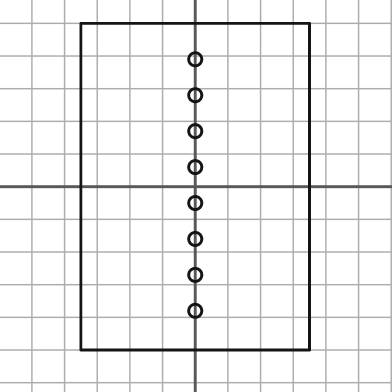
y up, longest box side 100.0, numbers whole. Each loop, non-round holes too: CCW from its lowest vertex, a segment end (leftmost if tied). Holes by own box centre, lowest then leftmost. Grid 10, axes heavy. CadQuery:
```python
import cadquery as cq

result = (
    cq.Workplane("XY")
    .moveTo(-35.0, -50.0)
    .lineTo(35.0, -50.0)
    .lineTo(35.0, 50.0)
    .lineTo(-35.0, 50.0)
    .close()
    .moveTo(0.0, -38.0)
    .circle(2.0)
    .moveTo(0.0, -27.0)
    .circle(2.0)
    .moveTo(0.0, -16.0)
    .circle(2.0)
    .moveTo(0.0, -5.0)
    .circle(2.0)
    .moveTo(0.0, 6.0)
    .circle(2.0)
    .moveTo(0.0, 17.0)
    .circle(2.0)
    .moveTo(0.0, 28.0)
    .circle(2.0)
    .moveTo(0.0, 39.0)
    .circle(2.0)
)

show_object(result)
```